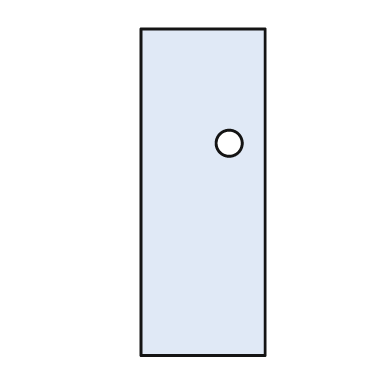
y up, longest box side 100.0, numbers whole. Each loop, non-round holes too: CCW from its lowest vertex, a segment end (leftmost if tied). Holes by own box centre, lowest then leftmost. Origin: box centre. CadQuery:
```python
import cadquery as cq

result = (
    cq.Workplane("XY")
    .moveTo(-19.0, -50.0)
    .lineTo(19.0, -50.0)
    .lineTo(19.0, 50.0)
    .lineTo(-19.0, 50.0)
    .close()
    .moveTo(8.0, 15.0)
    .circle(4.0)
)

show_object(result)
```